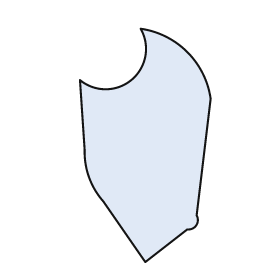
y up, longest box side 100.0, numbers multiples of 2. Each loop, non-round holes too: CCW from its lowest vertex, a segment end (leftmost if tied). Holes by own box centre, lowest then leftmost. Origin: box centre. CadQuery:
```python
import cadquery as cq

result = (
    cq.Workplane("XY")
    .moveTo(0.0, -50.0)
    .lineTo(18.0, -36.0)
    .threePointArc((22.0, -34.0), (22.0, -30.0))
    .lineTo(28.0, 20.0)
    .threePointArc((18.0, 40.0), (-2.0, 50.0))
    .threePointArc((-6.0, 28.0), (-28.0, 28.0))
    .lineTo(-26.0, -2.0)
    .threePointArc((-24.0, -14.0), (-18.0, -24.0))
    .close()
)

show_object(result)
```